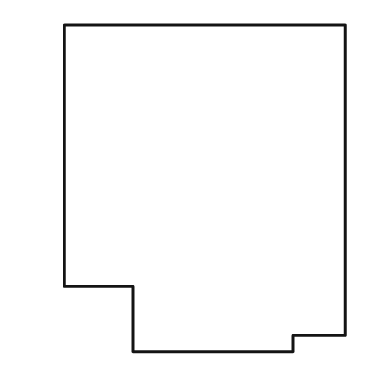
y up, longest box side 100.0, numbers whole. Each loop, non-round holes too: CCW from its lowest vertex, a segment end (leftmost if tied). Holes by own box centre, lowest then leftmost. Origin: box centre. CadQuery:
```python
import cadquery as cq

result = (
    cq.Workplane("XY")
    .moveTo(-22.0, -50.0)
    .lineTo(27.0, -50.0)
    .lineTo(27.0, -45.0)
    .lineTo(43.0, -45.0)
    .lineTo(43.0, 50.0)
    .lineTo(-43.0, 50.0)
    .lineTo(-43.0, -30.0)
    .lineTo(-22.0, -30.0)
    .close()
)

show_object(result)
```